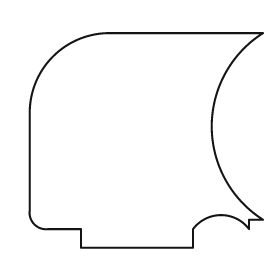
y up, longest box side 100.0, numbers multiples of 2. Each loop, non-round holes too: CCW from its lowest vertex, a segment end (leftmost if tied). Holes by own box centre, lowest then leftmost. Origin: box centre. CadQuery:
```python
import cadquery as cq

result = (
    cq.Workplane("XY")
    .moveTo(-28.0, -46.0)
    .lineTo(20.0, -46.0)
    .lineTo(20.0, -38.0)
    .threePointArc((32.0, -32.0), (44.0, -38.0))
    .lineTo(44.0, -34.0)
    .lineTo(50.0, -34.0)
    .threePointArc((28.0, 6.0), (50.0, 46.0))
    .lineTo(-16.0, 46.0)
    .threePointArc((-40.0, 36.0), (-50.0, 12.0))
    .lineTo(-50.0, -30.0)
    .threePointArc((-48.0, -36.0), (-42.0, -38.0))
    .lineTo(-28.0, -38.0)
    .close()
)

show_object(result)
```